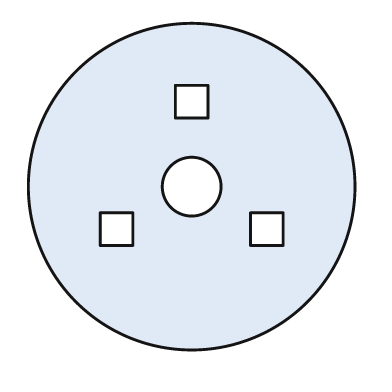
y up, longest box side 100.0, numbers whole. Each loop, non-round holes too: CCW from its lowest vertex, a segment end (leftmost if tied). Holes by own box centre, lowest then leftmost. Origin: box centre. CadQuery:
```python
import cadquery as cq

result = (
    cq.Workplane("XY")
    .moveTo(0.0, 0.0)
    .circle(50.0)
    .moveTo(-28.0, -18.0)
    .lineTo(-18.0, -18.0)
    .lineTo(-18.0, -8.0)
    .lineTo(-28.0, -8.0)
    .close()
    .moveTo(18.0, -18.0)
    .lineTo(28.0, -18.0)
    .lineTo(28.0, -8.0)
    .lineTo(18.0, -8.0)
    .close()
    .moveTo(0.0, 0.0)
    .circle(9.0)
    .moveTo(-5.0, 21.0)
    .lineTo(5.0, 21.0)
    .lineTo(5.0, 31.0)
    .lineTo(-5.0, 31.0)
    .close()
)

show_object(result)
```